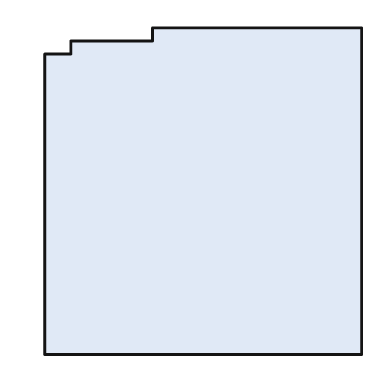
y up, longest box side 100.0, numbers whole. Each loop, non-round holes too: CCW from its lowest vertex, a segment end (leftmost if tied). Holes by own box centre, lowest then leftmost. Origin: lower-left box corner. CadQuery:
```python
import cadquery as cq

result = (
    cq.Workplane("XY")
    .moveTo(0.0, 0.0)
    .lineTo(97.0, 0.0)
    .lineTo(97.0, 100.0)
    .lineTo(33.0, 100.0)
    .lineTo(33.0, 96.0)
    .lineTo(8.0, 96.0)
    .lineTo(8.0, 92.0)
    .lineTo(0.0, 92.0)
    .close()
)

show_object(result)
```